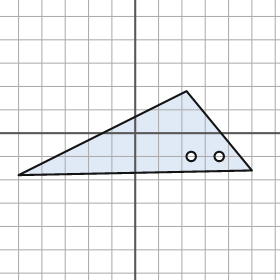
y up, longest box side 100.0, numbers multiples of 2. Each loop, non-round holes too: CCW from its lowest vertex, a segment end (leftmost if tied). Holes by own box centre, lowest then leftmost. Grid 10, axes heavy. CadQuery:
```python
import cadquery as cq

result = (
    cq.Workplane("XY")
    .moveTo(-50.0, -18.0)
    .lineTo(50.0, -16.0)
    .lineTo(22.0, 18.0)
    .close()
    .moveTo(24.0, -10.0)
    .circle(2.0)
    .moveTo(36.0, -10.0)
    .circle(2.0)
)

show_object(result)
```